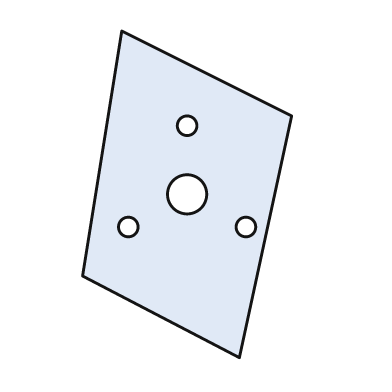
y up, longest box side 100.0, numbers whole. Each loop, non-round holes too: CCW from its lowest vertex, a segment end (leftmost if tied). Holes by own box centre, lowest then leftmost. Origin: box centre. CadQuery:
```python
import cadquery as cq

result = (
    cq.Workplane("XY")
    .moveTo(16.0, -50.0)
    .lineTo(32.0, 24.0)
    .lineTo(-20.0, 50.0)
    .lineTo(-32.0, -25.0)
    .close()
    .moveTo(-18.0, -10.0)
    .circle(3.0)
    .moveTo(18.0, -10.0)
    .circle(3.0)
    .moveTo(0.0, 0.0)
    .circle(6.0)
    .moveTo(0.0, 21.0)
    .circle(3.0)
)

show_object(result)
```